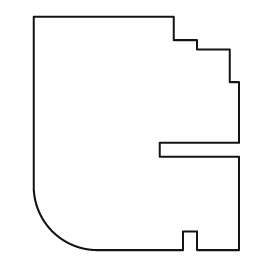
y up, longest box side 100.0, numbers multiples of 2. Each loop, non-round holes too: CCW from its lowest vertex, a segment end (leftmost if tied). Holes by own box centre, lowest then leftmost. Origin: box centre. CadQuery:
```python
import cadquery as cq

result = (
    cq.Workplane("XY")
    .moveTo(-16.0, -50.0)
    .lineTo(20.0, -50.0)
    .lineTo(20.0, -42.0)
    .lineTo(26.0, -42.0)
    .lineTo(26.0, -50.0)
    .lineTo(44.0, -50.0)
    .lineTo(44.0, -10.0)
    .lineTo(10.0, -10.0)
    .lineTo(10.0, -4.0)
    .lineTo(44.0, -4.0)
    .lineTo(44.0, 22.0)
    .lineTo(40.0, 22.0)
    .lineTo(40.0, 36.0)
    .lineTo(26.0, 36.0)
    .lineTo(26.0, 40.0)
    .lineTo(16.0, 40.0)
    .lineTo(16.0, 50.0)
    .lineTo(-44.0, 50.0)
    .lineTo(-44.0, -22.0)
    .threePointArc((-36.0, -42.0), (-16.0, -50.0))
    .close()
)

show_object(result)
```